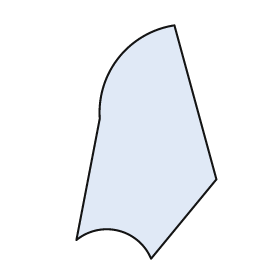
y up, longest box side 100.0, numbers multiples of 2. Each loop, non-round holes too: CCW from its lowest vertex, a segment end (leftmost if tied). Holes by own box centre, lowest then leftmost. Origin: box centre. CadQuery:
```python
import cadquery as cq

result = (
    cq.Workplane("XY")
    .moveTo(2.0, -50.0)
    .lineTo(30.0, -16.0)
    .lineTo(12.0, 50.0)
    .threePointArc((-12.0, 36.0), (-20.0, 10.0))
    .lineTo(-30.0, -42.0)
    .threePointArc((-12.0, -38.0), (2.0, -50.0))
    .close()
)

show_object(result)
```